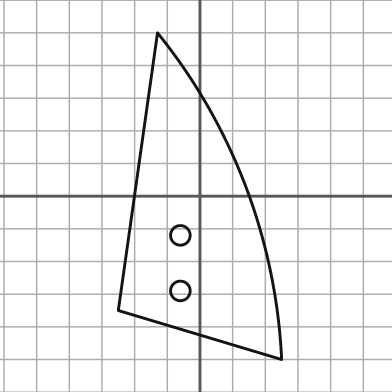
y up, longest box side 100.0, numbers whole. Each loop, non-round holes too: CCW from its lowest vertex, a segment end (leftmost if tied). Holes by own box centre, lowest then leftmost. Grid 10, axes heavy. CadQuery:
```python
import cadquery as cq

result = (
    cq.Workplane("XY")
    .moveTo(25.0, -50.0)
    .threePointArc((14.0, 3.0), (-13.0, 50.0))
    .lineTo(-25.0, -35.0)
    .close()
    .moveTo(-6.0, -29.0)
    .circle(3.0)
    .moveTo(-6.0, -12.0)
    .circle(3.0)
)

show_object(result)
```